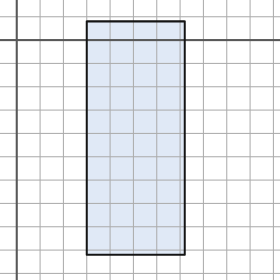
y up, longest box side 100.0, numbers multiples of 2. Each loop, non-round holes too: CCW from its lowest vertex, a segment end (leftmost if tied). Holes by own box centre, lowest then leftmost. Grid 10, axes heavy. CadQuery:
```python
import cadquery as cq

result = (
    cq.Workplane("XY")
    .moveTo(30.0, -92.0)
    .lineTo(72.0, -92.0)
    .lineTo(72.0, 8.0)
    .lineTo(30.0, 8.0)
    .close()
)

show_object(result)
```